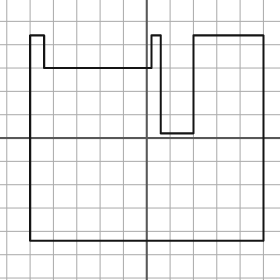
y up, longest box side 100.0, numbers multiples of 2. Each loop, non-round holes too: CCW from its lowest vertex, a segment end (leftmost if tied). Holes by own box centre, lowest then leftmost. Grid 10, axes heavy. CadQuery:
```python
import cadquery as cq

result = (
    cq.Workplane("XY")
    .moveTo(-50.0, -44.0)
    .lineTo(50.0, -44.0)
    .lineTo(50.0, 44.0)
    .lineTo(20.0, 44.0)
    .lineTo(20.0, 2.0)
    .lineTo(6.0, 2.0)
    .lineTo(6.0, 44.0)
    .lineTo(2.0, 44.0)
    .lineTo(2.0, 30.0)
    .lineTo(-44.0, 30.0)
    .lineTo(-44.0, 44.0)
    .lineTo(-50.0, 44.0)
    .close()
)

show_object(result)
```